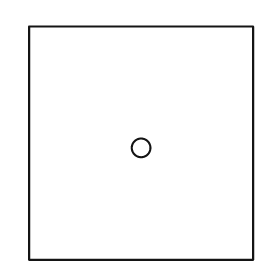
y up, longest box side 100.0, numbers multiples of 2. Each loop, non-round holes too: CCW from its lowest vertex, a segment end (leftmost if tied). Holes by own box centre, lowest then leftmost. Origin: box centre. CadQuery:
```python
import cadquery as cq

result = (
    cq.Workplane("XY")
    .moveTo(-48.0, -50.0)
    .lineTo(48.0, -50.0)
    .lineTo(48.0, 50.0)
    .lineTo(-48.0, 50.0)
    .close()
    .moveTo(0.0, -2.0)
    .circle(4.0)
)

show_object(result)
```